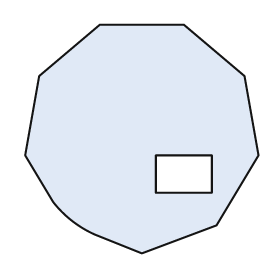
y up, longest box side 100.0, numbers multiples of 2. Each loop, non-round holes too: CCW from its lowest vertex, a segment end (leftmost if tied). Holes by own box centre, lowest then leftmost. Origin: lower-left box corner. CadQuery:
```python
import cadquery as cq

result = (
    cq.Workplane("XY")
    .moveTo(50.0, 0.0)
    .lineTo(82.0, 12.0)
    .lineTo(100.0, 42.0)
    .lineTo(94.0, 76.0)
    .lineTo(68.0, 98.0)
    .lineTo(32.0, 98.0)
    .lineTo(6.0, 76.0)
    .lineTo(0.0, 42.0)
    .lineTo(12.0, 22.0)
    .threePointArc((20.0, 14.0), (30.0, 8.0))
    .close()
    .moveTo(56.0, 26.0)
    .lineTo(80.0, 26.0)
    .lineTo(80.0, 42.0)
    .lineTo(56.0, 42.0)
    .close()
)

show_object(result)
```